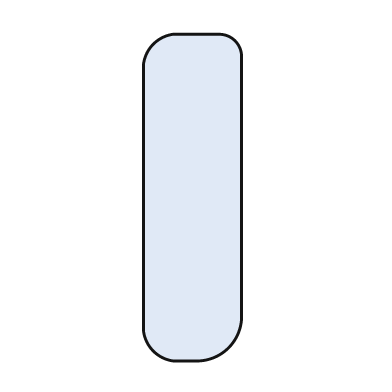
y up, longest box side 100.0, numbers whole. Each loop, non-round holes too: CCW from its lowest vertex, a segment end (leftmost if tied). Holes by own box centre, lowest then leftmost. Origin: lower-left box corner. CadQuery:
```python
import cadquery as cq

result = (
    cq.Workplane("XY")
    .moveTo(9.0, 0.0)
    .lineTo(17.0, 0.0)
    .threePointArc((26.0, 4.0), (30.0, 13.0))
    .lineTo(30.0, 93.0)
    .threePointArc((28.0, 98.0), (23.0, 100.0))
    .lineTo(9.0, 100.0)
    .threePointArc((3.0, 97.0), (0.0, 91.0))
    .lineTo(0.0, 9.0)
    .threePointArc((3.0, 3.0), (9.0, 0.0))
    .close()
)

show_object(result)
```